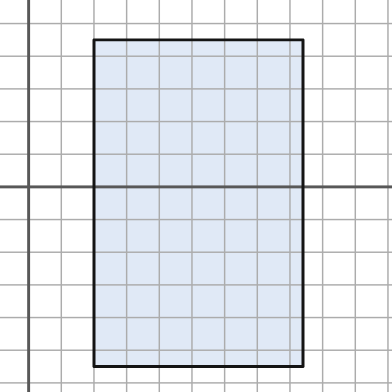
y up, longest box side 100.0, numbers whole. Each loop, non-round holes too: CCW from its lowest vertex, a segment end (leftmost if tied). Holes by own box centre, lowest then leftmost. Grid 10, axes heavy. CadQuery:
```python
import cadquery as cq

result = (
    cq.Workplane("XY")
    .moveTo(20.0, -55.0)
    .lineTo(84.0, -55.0)
    .lineTo(84.0, 45.0)
    .lineTo(20.0, 45.0)
    .close()
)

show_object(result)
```